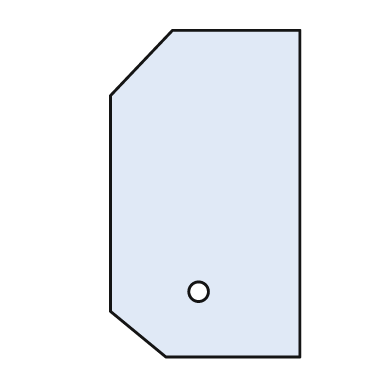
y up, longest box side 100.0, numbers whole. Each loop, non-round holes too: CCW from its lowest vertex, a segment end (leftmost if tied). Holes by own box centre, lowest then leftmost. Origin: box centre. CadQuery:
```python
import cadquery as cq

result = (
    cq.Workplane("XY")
    .moveTo(-12.0, -50.0)
    .lineTo(29.0, -50.0)
    .lineTo(29.0, 50.0)
    .lineTo(-10.0, 50.0)
    .lineTo(-29.0, 30.0)
    .lineTo(-29.0, -36.0)
    .close()
    .moveTo(-2.0, -30.0)
    .circle(3.0)
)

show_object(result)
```